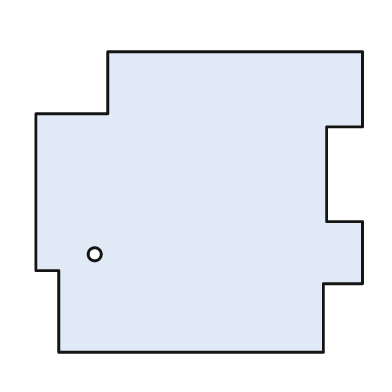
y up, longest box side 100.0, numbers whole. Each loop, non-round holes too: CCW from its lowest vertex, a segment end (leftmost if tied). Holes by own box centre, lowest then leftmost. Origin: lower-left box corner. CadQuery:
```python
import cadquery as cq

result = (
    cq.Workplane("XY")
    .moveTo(7.0, 0.0)
    .lineTo(88.0, 0.0)
    .lineTo(88.0, 21.0)
    .lineTo(100.0, 21.0)
    .lineTo(100.0, 40.0)
    .lineTo(89.0, 40.0)
    .lineTo(89.0, 69.0)
    .lineTo(100.0, 69.0)
    .lineTo(100.0, 92.0)
    .lineTo(22.0, 92.0)
    .lineTo(22.0, 73.0)
    .lineTo(0.0, 73.0)
    .lineTo(0.0, 25.0)
    .lineTo(7.0, 25.0)
    .close()
    .moveTo(18.0, 30.0)
    .circle(2.0)
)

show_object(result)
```